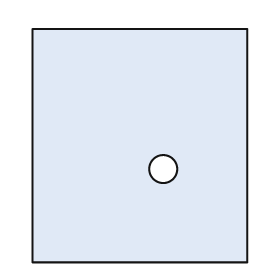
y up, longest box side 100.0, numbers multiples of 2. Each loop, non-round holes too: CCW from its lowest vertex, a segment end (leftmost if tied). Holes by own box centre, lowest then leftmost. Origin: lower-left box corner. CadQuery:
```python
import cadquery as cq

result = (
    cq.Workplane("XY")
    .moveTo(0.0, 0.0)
    .lineTo(92.0, 0.0)
    .lineTo(92.0, 100.0)
    .lineTo(0.0, 100.0)
    .close()
    .moveTo(56.0, 40.0)
    .circle(6.0)
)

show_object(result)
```